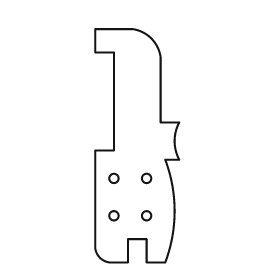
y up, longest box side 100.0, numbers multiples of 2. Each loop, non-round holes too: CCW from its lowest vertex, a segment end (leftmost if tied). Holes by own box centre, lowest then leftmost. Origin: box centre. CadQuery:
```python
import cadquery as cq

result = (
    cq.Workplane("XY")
    .moveTo(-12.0, -50.0)
    .lineTo(-4.0, -50.0)
    .lineTo(-4.0, -40.0)
    .lineTo(4.0, -40.0)
    .lineTo(4.0, -50.0)
    .lineTo(12.0, -50.0)
    .threePointArc((16.0, -28.0), (12.0, -6.0))
    .lineTo(18.0, -6.0)
    .threePointArc((16.0, 2.0), (18.0, 10.0))
    .lineTo(10.0, 10.0)
    .lineTo(10.0, 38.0)
    .threePointArc((6.0, 46.0), (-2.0, 50.0))
    .lineTo(-18.0, 50.0)
    .lineTo(-18.0, 40.0)
    .lineTo(-10.0, 40.0)
    .lineTo(-10.0, -2.0)
    .lineTo(-18.0, -2.0)
    .lineTo(-18.0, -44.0)
    .threePointArc((-16.0, -48.0), (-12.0, -50.0))
    .close()
    .moveTo(-10.0, -30.0)
    .circle(2.0)
    .moveTo(4.0, -30.0)
    .circle(2.0)
    .moveTo(-10.0, -14.0)
    .circle(2.0)
    .moveTo(4.0, -14.0)
    .circle(2.0)
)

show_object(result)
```